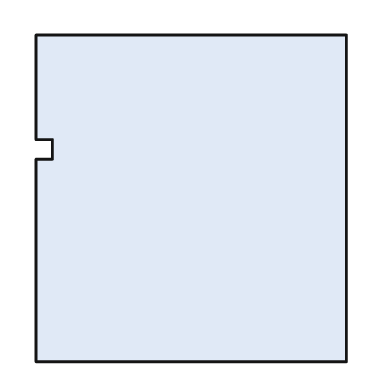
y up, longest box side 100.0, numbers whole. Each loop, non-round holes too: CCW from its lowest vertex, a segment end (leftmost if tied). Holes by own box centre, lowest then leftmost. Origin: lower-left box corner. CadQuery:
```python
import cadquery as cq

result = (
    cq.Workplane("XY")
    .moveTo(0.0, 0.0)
    .lineTo(95.0, 0.0)
    .lineTo(95.0, 100.0)
    .lineTo(0.0, 100.0)
    .lineTo(0.0, 68.0)
    .lineTo(5.0, 68.0)
    .lineTo(5.0, 62.0)
    .lineTo(0.0, 62.0)
    .close()
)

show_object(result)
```